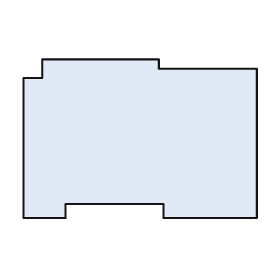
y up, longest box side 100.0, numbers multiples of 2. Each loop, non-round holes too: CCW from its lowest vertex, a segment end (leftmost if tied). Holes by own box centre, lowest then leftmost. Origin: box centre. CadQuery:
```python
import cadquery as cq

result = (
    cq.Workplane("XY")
    .moveTo(-50.0, -34.0)
    .lineTo(-32.0, -34.0)
    .lineTo(-32.0, -28.0)
    .lineTo(10.0, -28.0)
    .lineTo(10.0, -34.0)
    .lineTo(50.0, -34.0)
    .lineTo(50.0, 30.0)
    .lineTo(8.0, 30.0)
    .lineTo(8.0, 34.0)
    .lineTo(-42.0, 34.0)
    .lineTo(-42.0, 26.0)
    .lineTo(-50.0, 26.0)
    .close()
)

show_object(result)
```